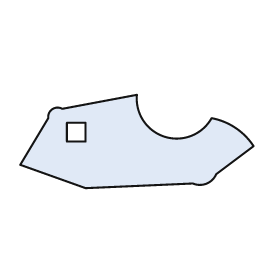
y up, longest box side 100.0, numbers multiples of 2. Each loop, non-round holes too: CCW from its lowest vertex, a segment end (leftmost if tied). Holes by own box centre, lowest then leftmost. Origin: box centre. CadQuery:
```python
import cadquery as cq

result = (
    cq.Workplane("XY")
    .moveTo(-22.0, -20.0)
    .lineTo(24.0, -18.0)
    .threePointArc((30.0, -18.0), (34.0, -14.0))
    .lineTo(50.0, -2.0)
    .threePointArc((42.0, 6.0), (32.0, 10.0))
    .threePointArc((12.0, 2.0), (0.0, 20.0))
    .lineTo(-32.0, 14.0)
    .threePointArc((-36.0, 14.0), (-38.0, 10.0))
    .lineTo(-50.0, -10.0)
    .close()
    .moveTo(-30.0, 0.0)
    .lineTo(-22.0, 0.0)
    .lineTo(-22.0, 8.0)
    .lineTo(-30.0, 8.0)
    .close()
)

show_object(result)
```